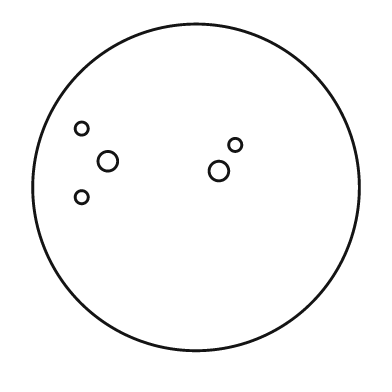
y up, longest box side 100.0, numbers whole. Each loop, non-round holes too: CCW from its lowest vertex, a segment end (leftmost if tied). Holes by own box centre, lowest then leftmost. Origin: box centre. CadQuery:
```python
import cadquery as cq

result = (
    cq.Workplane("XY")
    .moveTo(0.0, 0.0)
    .circle(50.0)
    .moveTo(-35.0, -3.0)
    .circle(2.0)
    .moveTo(7.0, 5.0)
    .circle(3.0)
    .moveTo(-27.0, 8.0)
    .circle(3.0)
    .moveTo(12.0, 13.0)
    .circle(2.0)
    .moveTo(-35.0, 18.0)
    .circle(2.0)
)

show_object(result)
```